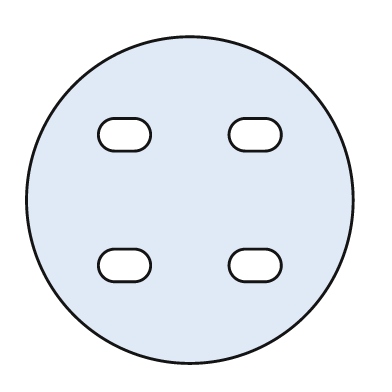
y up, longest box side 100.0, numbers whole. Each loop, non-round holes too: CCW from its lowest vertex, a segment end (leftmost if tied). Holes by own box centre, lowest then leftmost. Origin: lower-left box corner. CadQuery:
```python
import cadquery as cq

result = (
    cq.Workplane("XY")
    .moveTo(50.0, 50.0)
    .circle(50.0)
    .moveTo(27.0, 25.0)
    .lineTo(33.0, 25.0)
    .threePointArc((38.0, 30.0), (33.0, 35.0))
    .lineTo(27.0, 35.0)
    .threePointArc((22.0, 30.0), (27.0, 25.0))
    .close()
    .moveTo(67.0, 25.0)
    .lineTo(73.0, 25.0)
    .threePointArc((78.0, 30.0), (73.0, 35.0))
    .lineTo(67.0, 35.0)
    .threePointArc((62.0, 30.0), (67.0, 25.0))
    .close()
    .moveTo(27.0, 65.0)
    .lineTo(33.0, 65.0)
    .threePointArc((38.0, 70.0), (33.0, 75.0))
    .lineTo(27.0, 75.0)
    .threePointArc((22.0, 70.0), (27.0, 65.0))
    .close()
    .moveTo(67.0, 65.0)
    .lineTo(73.0, 65.0)
    .threePointArc((78.0, 70.0), (73.0, 75.0))
    .lineTo(67.0, 75.0)
    .threePointArc((62.0, 70.0), (67.0, 65.0))
    .close()
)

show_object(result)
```